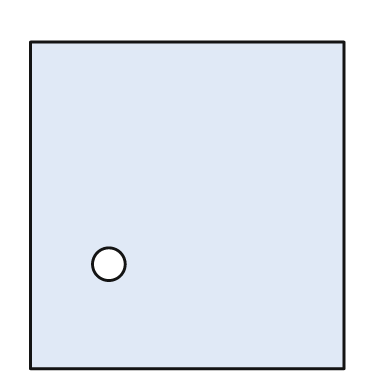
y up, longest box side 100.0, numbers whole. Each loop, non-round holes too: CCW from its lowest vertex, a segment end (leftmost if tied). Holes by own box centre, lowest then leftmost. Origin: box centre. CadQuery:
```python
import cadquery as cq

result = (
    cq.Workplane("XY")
    .moveTo(-48.0, -50.0)
    .lineTo(48.0, -50.0)
    .lineTo(48.0, 50.0)
    .lineTo(-48.0, 50.0)
    .close()
    .moveTo(-24.0, -18.0)
    .circle(5.0)
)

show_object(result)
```